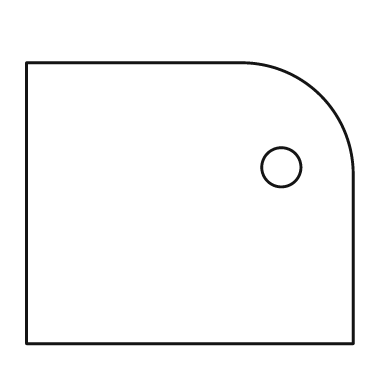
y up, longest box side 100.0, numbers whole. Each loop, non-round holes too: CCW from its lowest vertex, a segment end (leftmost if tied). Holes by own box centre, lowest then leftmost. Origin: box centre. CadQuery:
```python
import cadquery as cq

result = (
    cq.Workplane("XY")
    .moveTo(-50.0, -43.0)
    .lineTo(50.0, -43.0)
    .lineTo(50.0, 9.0)
    .threePointArc((40.0, 33.0), (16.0, 43.0))
    .lineTo(-50.0, 43.0)
    .close()
    .moveTo(28.0, 11.0)
    .circle(6.0)
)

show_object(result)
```